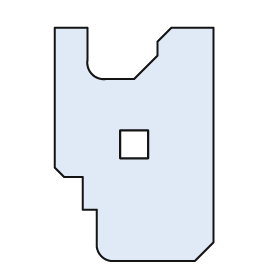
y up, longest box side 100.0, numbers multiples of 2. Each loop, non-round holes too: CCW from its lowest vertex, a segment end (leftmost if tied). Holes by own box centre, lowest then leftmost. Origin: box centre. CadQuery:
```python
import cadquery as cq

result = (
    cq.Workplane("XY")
    .moveTo(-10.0, -50.0)
    .lineTo(26.0, -50.0)
    .lineTo(34.0, -42.0)
    .lineTo(34.0, 50.0)
    .lineTo(16.0, 50.0)
    .lineTo(10.0, 44.0)
    .lineTo(10.0, 38.0)
    .lineTo(0.0, 28.0)
    .lineTo(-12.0, 28.0)
    .threePointArc((-18.0, 30.0), (-20.0, 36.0))
    .lineTo(-20.0, 50.0)
    .lineTo(-34.0, 50.0)
    .lineTo(-34.0, -10.0)
    .lineTo(-30.0, -14.0)
    .lineTo(-22.0, -14.0)
    .lineTo(-22.0, -28.0)
    .lineTo(-16.0, -28.0)
    .lineTo(-16.0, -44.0)
    .threePointArc((-14.0, -48.0), (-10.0, -50.0))
    .close()
    .moveTo(-6.0, -6.0)
    .lineTo(6.0, -6.0)
    .lineTo(6.0, 6.0)
    .lineTo(-6.0, 6.0)
    .close()
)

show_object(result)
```